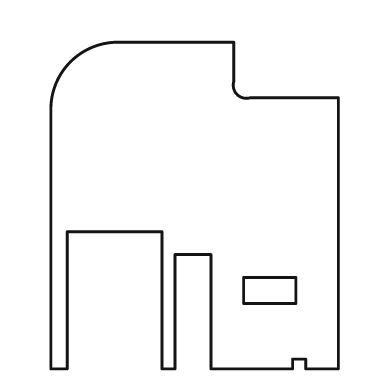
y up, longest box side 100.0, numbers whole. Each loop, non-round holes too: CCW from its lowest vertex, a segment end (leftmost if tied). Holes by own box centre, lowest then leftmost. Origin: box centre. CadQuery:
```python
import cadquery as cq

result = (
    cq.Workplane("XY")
    .moveTo(-44.0, -50.0)
    .lineTo(-39.0, -50.0)
    .lineTo(-39.0, -8.0)
    .lineTo(-10.0, -8.0)
    .lineTo(-10.0, -50.0)
    .lineTo(-6.0, -50.0)
    .lineTo(-6.0, -15.0)
    .lineTo(5.0, -15.0)
    .lineTo(5.0, -50.0)
    .lineTo(30.0, -50.0)
    .lineTo(30.0, -47.0)
    .lineTo(34.0, -47.0)
    .lineTo(34.0, -50.0)
    .lineTo(44.0, -50.0)
    .lineTo(44.0, 33.0)
    .lineTo(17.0, 33.0)
    .threePointArc((13.0, 34.0), (12.0, 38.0))
    .lineTo(12.0, 50.0)
    .lineTo(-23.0, 50.0)
    .threePointArc((-38.0, 44.0), (-44.0, 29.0))
    .close()
    .moveTo(15.0, -30.0)
    .lineTo(31.0, -30.0)
    .lineTo(31.0, -22.0)
    .lineTo(15.0, -22.0)
    .close()
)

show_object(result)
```